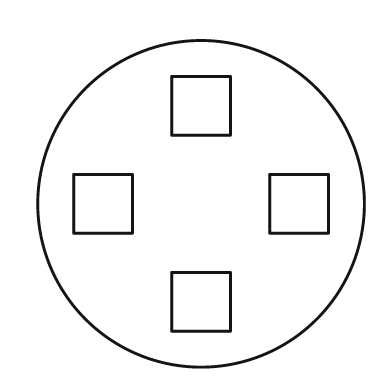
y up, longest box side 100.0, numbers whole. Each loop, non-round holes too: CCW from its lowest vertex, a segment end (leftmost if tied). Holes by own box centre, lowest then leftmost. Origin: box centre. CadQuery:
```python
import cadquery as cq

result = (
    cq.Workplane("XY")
    .moveTo(0.0, 0.0)
    .circle(50.0)
    .moveTo(-9.0, -39.0)
    .lineTo(9.0, -39.0)
    .lineTo(9.0, -21.0)
    .lineTo(-9.0, -21.0)
    .close()
    .moveTo(-39.0, -9.0)
    .lineTo(-21.0, -9.0)
    .lineTo(-21.0, 9.0)
    .lineTo(-39.0, 9.0)
    .close()
    .moveTo(21.0, -9.0)
    .lineTo(39.0, -9.0)
    .lineTo(39.0, 9.0)
    .lineTo(21.0, 9.0)
    .close()
    .moveTo(-9.0, 21.0)
    .lineTo(9.0, 21.0)
    .lineTo(9.0, 39.0)
    .lineTo(-9.0, 39.0)
    .close()
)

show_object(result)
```